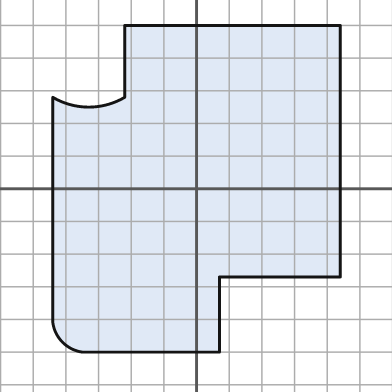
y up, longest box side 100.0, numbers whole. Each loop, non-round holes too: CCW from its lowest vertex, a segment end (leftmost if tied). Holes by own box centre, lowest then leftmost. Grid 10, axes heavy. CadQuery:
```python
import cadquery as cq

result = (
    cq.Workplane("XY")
    .moveTo(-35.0, -50.0)
    .lineTo(7.0, -50.0)
    .lineTo(7.0, -27.0)
    .lineTo(44.0, -27.0)
    .lineTo(44.0, 50.0)
    .lineTo(-22.0, 50.0)
    .lineTo(-22.0, 28.0)
    .threePointArc((-33.0, 25.0), (-44.0, 28.0))
    .lineTo(-44.0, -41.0)
    .threePointArc((-41.0, -47.0), (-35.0, -50.0))
    .close()
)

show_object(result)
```